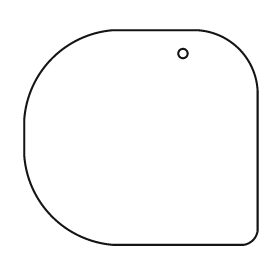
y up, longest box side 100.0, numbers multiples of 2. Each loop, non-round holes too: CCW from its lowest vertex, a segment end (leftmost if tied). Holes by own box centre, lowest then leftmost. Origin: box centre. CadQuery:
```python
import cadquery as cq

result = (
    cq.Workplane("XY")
    .moveTo(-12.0, -46.0)
    .lineTo(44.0, -46.0)
    .threePointArc((48.0, -44.0), (50.0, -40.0))
    .lineTo(50.0, 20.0)
    .threePointArc((42.0, 38.0), (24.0, 46.0))
    .lineTo(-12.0, 46.0)
    .threePointArc((-38.0, 34.0), (-50.0, 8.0))
    .lineTo(-50.0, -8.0)
    .threePointArc((-38.0, -34.0), (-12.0, -46.0))
    .close()
    .moveTo(18.0, 36.0)
    .circle(2.0)
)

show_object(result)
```